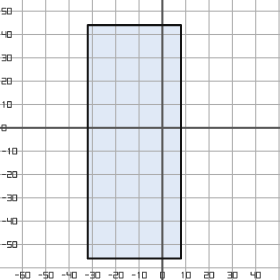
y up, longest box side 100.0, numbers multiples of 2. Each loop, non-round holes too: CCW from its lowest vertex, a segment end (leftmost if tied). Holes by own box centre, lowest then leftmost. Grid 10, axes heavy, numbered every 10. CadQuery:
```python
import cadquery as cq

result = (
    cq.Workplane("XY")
    .moveTo(-32.0, -56.0)
    .lineTo(8.0, -56.0)
    .lineTo(8.0, 44.0)
    .lineTo(-32.0, 44.0)
    .close()
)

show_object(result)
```